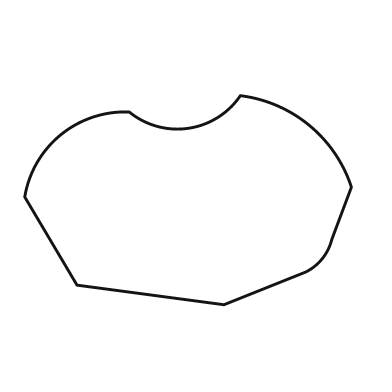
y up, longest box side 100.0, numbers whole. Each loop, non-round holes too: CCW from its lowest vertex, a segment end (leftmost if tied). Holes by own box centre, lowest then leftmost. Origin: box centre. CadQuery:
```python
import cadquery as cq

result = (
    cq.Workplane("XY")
    .moveTo(11.0, -32.0)
    .lineTo(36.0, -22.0)
    .threePointArc((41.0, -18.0), (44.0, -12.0))
    .lineTo(50.0, 4.0)
    .threePointArc((37.0, 23.0), (16.0, 32.0))
    .threePointArc((0.0, 22.0), (-18.0, 27.0))
    .threePointArc((-39.0, 20.0), (-50.0, 1.0))
    .lineTo(-34.0, -26.0)
    .close()
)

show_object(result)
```